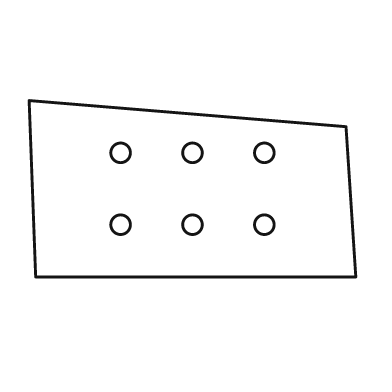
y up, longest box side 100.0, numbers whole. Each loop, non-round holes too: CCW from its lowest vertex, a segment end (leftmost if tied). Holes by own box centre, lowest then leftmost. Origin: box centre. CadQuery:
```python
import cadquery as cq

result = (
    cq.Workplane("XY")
    .moveTo(-48.0, -27.0)
    .lineTo(50.0, -27.0)
    .lineTo(47.0, 19.0)
    .lineTo(-50.0, 27.0)
    .close()
    .moveTo(-22.0, -11.0)
    .circle(3.0)
    .moveTo(0.0, -11.0)
    .circle(3.0)
    .moveTo(22.0, -11.0)
    .circle(3.0)
    .moveTo(-22.0, 11.0)
    .circle(3.0)
    .moveTo(0.0, 11.0)
    .circle(3.0)
    .moveTo(22.0, 11.0)
    .circle(3.0)
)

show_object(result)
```